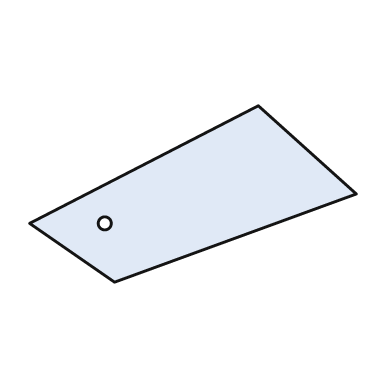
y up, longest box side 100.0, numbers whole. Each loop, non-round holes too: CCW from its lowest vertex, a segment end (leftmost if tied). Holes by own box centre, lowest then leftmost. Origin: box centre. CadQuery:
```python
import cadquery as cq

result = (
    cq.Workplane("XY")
    .moveTo(-24.0, -27.0)
    .lineTo(50.0, 0.0)
    .lineTo(20.0, 27.0)
    .lineTo(-50.0, -9.0)
    .close()
    .moveTo(-27.0, -9.0)
    .circle(2.0)
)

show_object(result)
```